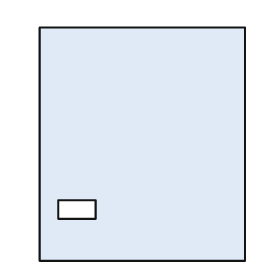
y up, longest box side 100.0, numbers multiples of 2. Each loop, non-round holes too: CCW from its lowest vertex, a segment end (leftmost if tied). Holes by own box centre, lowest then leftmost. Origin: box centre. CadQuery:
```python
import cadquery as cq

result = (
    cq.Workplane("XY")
    .moveTo(-44.0, -50.0)
    .lineTo(44.0, -50.0)
    .lineTo(44.0, 50.0)
    .lineTo(-44.0, 50.0)
    .close()
    .moveTo(-36.0, -32.0)
    .lineTo(-20.0, -32.0)
    .lineTo(-20.0, -24.0)
    .lineTo(-36.0, -24.0)
    .close()
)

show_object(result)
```